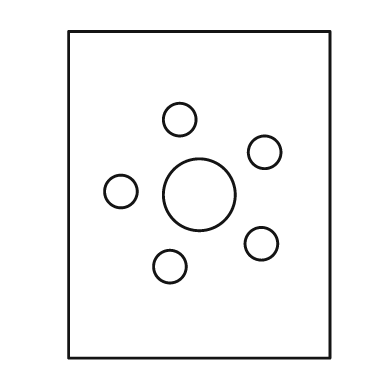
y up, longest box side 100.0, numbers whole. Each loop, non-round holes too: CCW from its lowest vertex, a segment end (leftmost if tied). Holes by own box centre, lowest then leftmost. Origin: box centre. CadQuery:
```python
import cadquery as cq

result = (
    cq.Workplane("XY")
    .moveTo(-40.0, -50.0)
    .lineTo(40.0, -50.0)
    .lineTo(40.0, 50.0)
    .lineTo(-40.0, 50.0)
    .close()
    .moveTo(-9.0, -22.0)
    .circle(5.0)
    .moveTo(19.0, -15.0)
    .circle(5.0)
    .moveTo(0.0, 0.0)
    .circle(11.0)
    .moveTo(-24.0, 1.0)
    .circle(5.0)
    .moveTo(20.0, 13.0)
    .circle(5.0)
    .moveTo(-6.0, 23.0)
    .circle(5.0)
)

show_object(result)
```